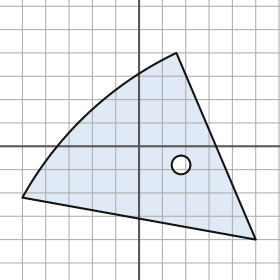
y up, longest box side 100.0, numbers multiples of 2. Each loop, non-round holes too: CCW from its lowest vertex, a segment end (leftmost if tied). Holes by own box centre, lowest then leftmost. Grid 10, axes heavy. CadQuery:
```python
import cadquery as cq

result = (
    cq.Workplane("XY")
    .moveTo(50.0, -40.0)
    .lineTo(16.0, 40.0)
    .threePointArc((-22.0, 14.0), (-50.0, -22.0))
    .close()
    .moveTo(18.0, -8.0)
    .circle(4.0)
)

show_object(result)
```